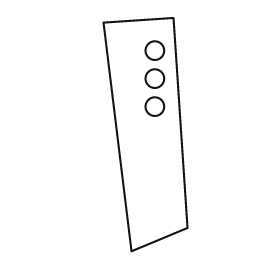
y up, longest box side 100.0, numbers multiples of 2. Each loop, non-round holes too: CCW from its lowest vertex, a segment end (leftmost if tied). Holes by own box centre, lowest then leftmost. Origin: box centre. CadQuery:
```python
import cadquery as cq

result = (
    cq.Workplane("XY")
    .moveTo(-6.0, -50.0)
    .lineTo(18.0, -40.0)
    .lineTo(12.0, 50.0)
    .lineTo(-18.0, 48.0)
    .close()
    .moveTo(4.0, 12.0)
    .circle(4.0)
    .moveTo(4.0, 24.0)
    .circle(4.0)
    .moveTo(4.0, 36.0)
    .circle(4.0)
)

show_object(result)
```